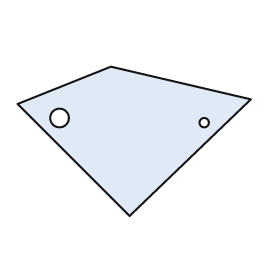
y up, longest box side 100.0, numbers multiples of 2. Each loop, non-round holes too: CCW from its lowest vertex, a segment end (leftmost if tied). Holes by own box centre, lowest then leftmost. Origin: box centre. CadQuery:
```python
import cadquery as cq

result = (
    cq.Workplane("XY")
    .moveTo(-2.0, -32.0)
    .lineTo(50.0, 18.0)
    .lineTo(-10.0, 32.0)
    .lineTo(-50.0, 16.0)
    .close()
    .moveTo(30.0, 8.0)
    .circle(2.0)
    .moveTo(-32.0, 10.0)
    .circle(4.0)
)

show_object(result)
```